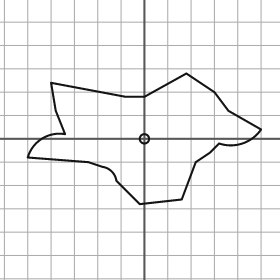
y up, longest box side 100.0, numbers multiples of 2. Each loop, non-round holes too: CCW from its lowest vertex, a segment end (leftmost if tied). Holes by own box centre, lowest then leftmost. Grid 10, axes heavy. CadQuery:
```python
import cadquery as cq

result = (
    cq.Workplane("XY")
    .moveTo(-2.0, -28.0)
    .lineTo(16.0, -26.0)
    .lineTo(22.0, -10.0)
    .lineTo(28.0, -6.0)
    .lineTo(32.0, -2.0)
    .threePointArc((42.0, -2.0), (50.0, 4.0))
    .lineTo(36.0, 12.0)
    .lineTo(30.0, 20.0)
    .lineTo(18.0, 28.0)
    .lineTo(0.0, 18.0)
    .lineTo(-8.0, 18.0)
    .lineTo(-40.0, 24.0)
    .lineTo(-38.0, 12.0)
    .lineTo(-34.0, 2.0)
    .threePointArc((-44.0, 0.0), (-50.0, -8.0))
    .lineTo(-24.0, -10.0)
    .lineTo(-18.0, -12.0)
    .threePointArc((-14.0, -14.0), (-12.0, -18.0))
    .close()
    .moveTo(0.0, 0.0)
    .circle(2.0)
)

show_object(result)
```